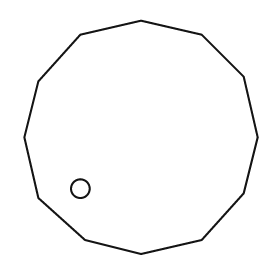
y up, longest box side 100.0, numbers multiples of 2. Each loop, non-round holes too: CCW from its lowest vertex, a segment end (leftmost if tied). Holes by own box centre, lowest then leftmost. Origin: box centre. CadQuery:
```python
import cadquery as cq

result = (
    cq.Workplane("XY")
    .moveTo(0.0, -50.0)
    .lineTo(26.0, -44.0)
    .lineTo(44.0, -24.0)
    .lineTo(50.0, 0.0)
    .lineTo(44.0, 26.0)
    .lineTo(26.0, 44.0)
    .lineTo(0.0, 50.0)
    .lineTo(-26.0, 44.0)
    .lineTo(-44.0, 24.0)
    .lineTo(-50.0, 0.0)
    .lineTo(-44.0, -26.0)
    .lineTo(-24.0, -44.0)
    .close()
    .moveTo(-26.0, -22.0)
    .circle(4.0)
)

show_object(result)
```